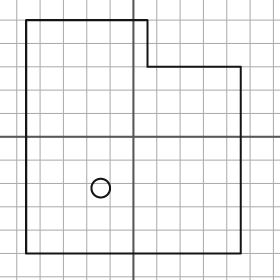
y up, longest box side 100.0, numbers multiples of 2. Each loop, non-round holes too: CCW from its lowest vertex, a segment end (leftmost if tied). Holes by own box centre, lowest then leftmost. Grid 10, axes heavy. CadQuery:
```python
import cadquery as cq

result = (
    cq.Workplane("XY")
    .moveTo(-46.0, -50.0)
    .lineTo(46.0, -50.0)
    .lineTo(46.0, 30.0)
    .lineTo(6.0, 30.0)
    .lineTo(6.0, 50.0)
    .lineTo(-46.0, 50.0)
    .close()
    .moveTo(-14.0, -22.0)
    .circle(4.0)
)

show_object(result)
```